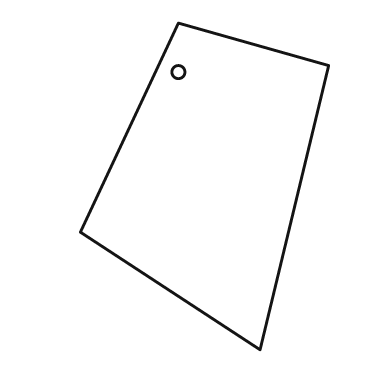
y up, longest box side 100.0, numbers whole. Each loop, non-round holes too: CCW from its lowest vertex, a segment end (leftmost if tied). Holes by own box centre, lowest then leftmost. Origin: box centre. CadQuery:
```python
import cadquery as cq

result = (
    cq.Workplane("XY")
    .moveTo(17.0, -50.0)
    .lineTo(38.0, 37.0)
    .lineTo(-8.0, 50.0)
    .lineTo(-38.0, -14.0)
    .close()
    .moveTo(-8.0, 35.0)
    .circle(2.0)
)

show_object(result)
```